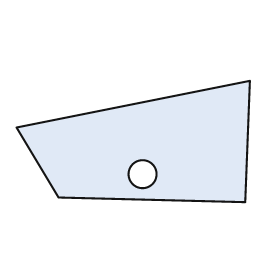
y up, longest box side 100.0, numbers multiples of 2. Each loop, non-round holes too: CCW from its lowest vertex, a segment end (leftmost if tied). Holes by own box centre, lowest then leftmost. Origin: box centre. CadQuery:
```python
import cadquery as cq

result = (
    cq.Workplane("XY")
    .moveTo(48.0, -26.0)
    .lineTo(50.0, 26.0)
    .lineTo(-50.0, 6.0)
    .lineTo(-32.0, -24.0)
    .close()
    .moveTo(4.0, -14.0)
    .circle(6.0)
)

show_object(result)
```